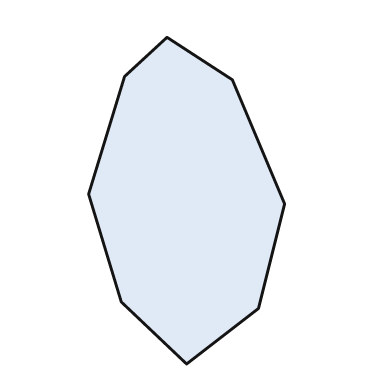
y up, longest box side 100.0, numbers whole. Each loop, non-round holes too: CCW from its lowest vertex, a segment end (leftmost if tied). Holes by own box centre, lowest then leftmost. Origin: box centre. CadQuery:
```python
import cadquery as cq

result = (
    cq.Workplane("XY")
    .moveTo(0.0, -50.0)
    .lineTo(22.0, -33.0)
    .lineTo(30.0, -1.0)
    .lineTo(14.0, 37.0)
    .lineTo(-6.0, 50.0)
    .lineTo(-19.0, 38.0)
    .lineTo(-30.0, 2.0)
    .lineTo(-20.0, -31.0)
    .close()
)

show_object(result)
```